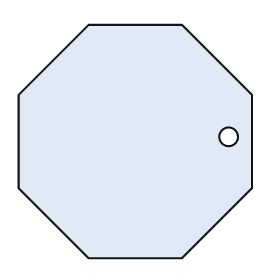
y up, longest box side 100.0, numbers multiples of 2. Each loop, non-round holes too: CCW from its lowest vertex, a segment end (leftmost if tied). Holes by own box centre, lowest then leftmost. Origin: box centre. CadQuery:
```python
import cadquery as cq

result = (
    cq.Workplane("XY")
    .moveTo(-20.0, -50.0)
    .lineTo(20.0, -50.0)
    .lineTo(50.0, -20.0)
    .lineTo(50.0, 20.0)
    .lineTo(20.0, 50.0)
    .lineTo(-20.0, 50.0)
    .lineTo(-50.0, 20.0)
    .lineTo(-50.0, -20.0)
    .close()
    .moveTo(40.0, 2.0)
    .circle(4.0)
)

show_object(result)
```